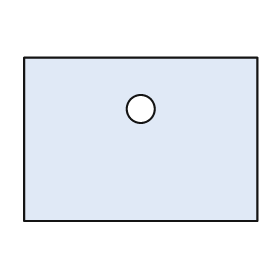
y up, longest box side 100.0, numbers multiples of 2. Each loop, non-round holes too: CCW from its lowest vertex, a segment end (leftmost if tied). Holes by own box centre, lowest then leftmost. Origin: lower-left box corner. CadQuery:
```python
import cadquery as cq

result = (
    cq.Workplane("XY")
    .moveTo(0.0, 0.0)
    .lineTo(100.0, 0.0)
    .lineTo(100.0, 70.0)
    .lineTo(0.0, 70.0)
    .close()
    .moveTo(50.0, 48.0)
    .circle(6.0)
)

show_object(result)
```